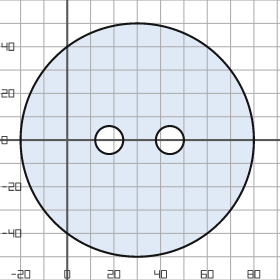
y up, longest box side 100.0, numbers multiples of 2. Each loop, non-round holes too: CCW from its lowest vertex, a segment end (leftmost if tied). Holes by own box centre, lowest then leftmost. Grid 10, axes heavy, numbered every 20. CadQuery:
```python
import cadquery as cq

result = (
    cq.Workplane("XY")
    .moveTo(30.0, 0.0)
    .circle(50.0)
    .moveTo(18.0, 0.0)
    .circle(6.0)
    .moveTo(44.0, 0.0)
    .circle(6.0)
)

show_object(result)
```